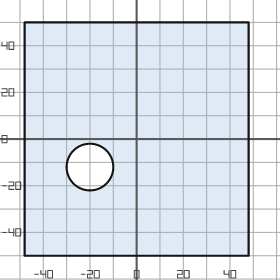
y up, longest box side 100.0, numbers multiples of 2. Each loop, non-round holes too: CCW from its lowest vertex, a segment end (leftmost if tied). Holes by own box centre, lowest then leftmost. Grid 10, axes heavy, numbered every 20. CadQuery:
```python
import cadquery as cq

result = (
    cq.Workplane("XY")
    .moveTo(-48.0, -50.0)
    .lineTo(48.0, -50.0)
    .lineTo(48.0, 50.0)
    .lineTo(-48.0, 50.0)
    .close()
    .moveTo(-20.0, -12.0)
    .circle(10.0)
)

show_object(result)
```